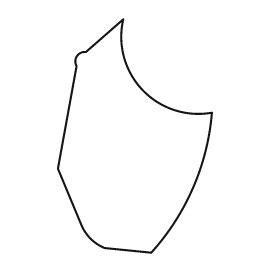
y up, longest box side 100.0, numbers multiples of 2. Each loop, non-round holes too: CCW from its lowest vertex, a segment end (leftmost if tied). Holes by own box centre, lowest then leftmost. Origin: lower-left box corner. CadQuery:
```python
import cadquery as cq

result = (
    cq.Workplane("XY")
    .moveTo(40.0, 0.0)
    .threePointArc((58.0, 28.0), (66.0, 60.0))
    .threePointArc((36.0, 70.0), (28.0, 100.0))
    .lineTo(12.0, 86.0)
    .threePointArc((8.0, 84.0), (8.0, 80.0))
    .lineTo(0.0, 36.0)
    .lineTo(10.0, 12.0)
    .threePointArc((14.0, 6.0), (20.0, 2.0))
    .close()
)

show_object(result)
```